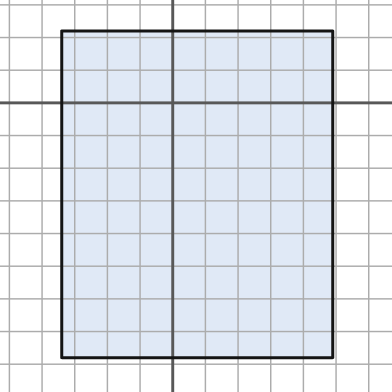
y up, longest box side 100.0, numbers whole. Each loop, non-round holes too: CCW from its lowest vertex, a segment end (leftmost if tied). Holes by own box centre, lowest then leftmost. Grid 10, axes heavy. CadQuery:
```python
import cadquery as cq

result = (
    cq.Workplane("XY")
    .moveTo(-34.0, -78.0)
    .lineTo(49.0, -78.0)
    .lineTo(49.0, 22.0)
    .lineTo(-34.0, 22.0)
    .close()
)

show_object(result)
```